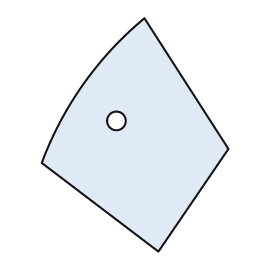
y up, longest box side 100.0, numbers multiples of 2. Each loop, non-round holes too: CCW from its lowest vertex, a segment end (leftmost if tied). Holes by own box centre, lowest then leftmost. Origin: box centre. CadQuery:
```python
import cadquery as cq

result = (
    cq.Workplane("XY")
    .moveTo(10.0, -50.0)
    .lineTo(40.0, -6.0)
    .lineTo(4.0, 50.0)
    .threePointArc((-22.0, 22.0), (-40.0, -12.0))
    .close()
    .moveTo(-8.0, 6.0)
    .circle(4.0)
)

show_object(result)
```